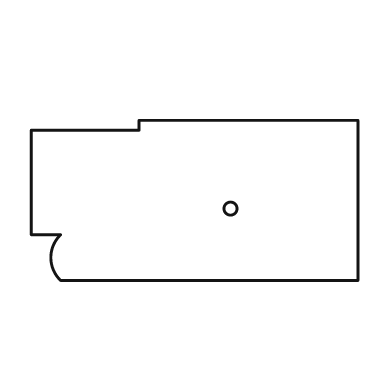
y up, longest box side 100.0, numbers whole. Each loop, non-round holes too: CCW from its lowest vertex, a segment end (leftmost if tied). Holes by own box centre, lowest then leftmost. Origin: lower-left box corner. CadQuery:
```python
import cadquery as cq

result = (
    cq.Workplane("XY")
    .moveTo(9.0, 0.0)
    .lineTo(100.0, 0.0)
    .lineTo(100.0, 49.0)
    .lineTo(33.0, 49.0)
    .lineTo(33.0, 46.0)
    .lineTo(0.0, 46.0)
    .lineTo(0.0, 14.0)
    .lineTo(9.0, 14.0)
    .threePointArc((6.0, 7.0), (9.0, 0.0))
    .close()
    .moveTo(61.0, 22.0)
    .circle(2.0)
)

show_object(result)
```